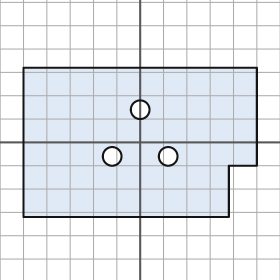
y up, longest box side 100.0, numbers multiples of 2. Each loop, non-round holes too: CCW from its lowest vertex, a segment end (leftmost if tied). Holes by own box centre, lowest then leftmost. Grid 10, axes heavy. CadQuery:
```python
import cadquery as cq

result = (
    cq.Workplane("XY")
    .moveTo(-50.0, -32.0)
    .lineTo(38.0, -32.0)
    .lineTo(38.0, -10.0)
    .lineTo(50.0, -10.0)
    .lineTo(50.0, 32.0)
    .lineTo(-50.0, 32.0)
    .close()
    .moveTo(-12.0, -6.0)
    .circle(4.0)
    .moveTo(12.0, -6.0)
    .circle(4.0)
    .moveTo(0.0, 14.0)
    .circle(4.0)
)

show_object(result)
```